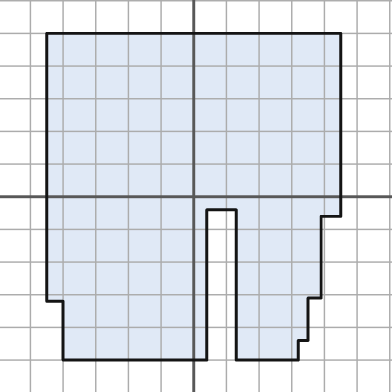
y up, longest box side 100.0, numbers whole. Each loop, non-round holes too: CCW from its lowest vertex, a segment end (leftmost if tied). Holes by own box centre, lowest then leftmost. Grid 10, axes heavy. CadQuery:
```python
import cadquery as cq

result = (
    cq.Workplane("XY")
    .moveTo(-40.0, -50.0)
    .lineTo(4.0, -50.0)
    .lineTo(4.0, -4.0)
    .lineTo(13.0, -4.0)
    .lineTo(13.0, -50.0)
    .lineTo(32.0, -50.0)
    .lineTo(32.0, -44.0)
    .lineTo(35.0, -44.0)
    .lineTo(35.0, -31.0)
    .lineTo(39.0, -31.0)
    .lineTo(39.0, -6.0)
    .lineTo(45.0, -6.0)
    .lineTo(45.0, 50.0)
    .lineTo(-45.0, 50.0)
    .lineTo(-45.0, -32.0)
    .lineTo(-40.0, -32.0)
    .close()
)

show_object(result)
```